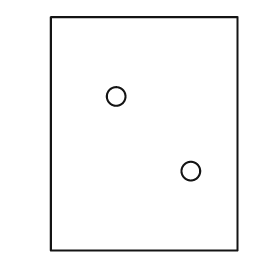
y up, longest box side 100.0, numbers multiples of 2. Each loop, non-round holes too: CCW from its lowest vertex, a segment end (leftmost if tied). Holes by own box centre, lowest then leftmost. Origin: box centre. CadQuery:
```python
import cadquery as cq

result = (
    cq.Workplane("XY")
    .moveTo(-40.0, -50.0)
    .lineTo(40.0, -50.0)
    .lineTo(40.0, 50.0)
    .lineTo(-40.0, 50.0)
    .close()
    .moveTo(20.0, -16.0)
    .circle(4.0)
    .moveTo(-12.0, 16.0)
    .circle(4.0)
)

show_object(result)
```